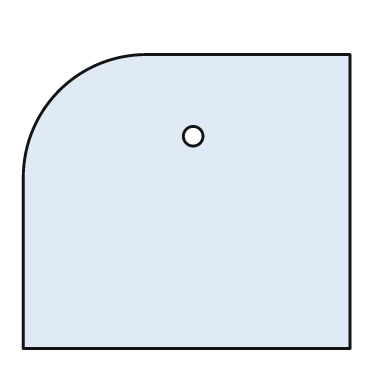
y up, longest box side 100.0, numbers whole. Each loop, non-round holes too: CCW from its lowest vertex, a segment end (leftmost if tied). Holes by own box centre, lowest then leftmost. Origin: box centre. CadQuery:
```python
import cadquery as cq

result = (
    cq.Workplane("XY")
    .moveTo(-50.0, -45.0)
    .lineTo(50.0, -45.0)
    .lineTo(50.0, 45.0)
    .lineTo(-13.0, 45.0)
    .threePointArc((-39.0, 34.0), (-50.0, 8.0))
    .close()
    .moveTo(2.0, 20.0)
    .circle(3.0)
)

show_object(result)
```